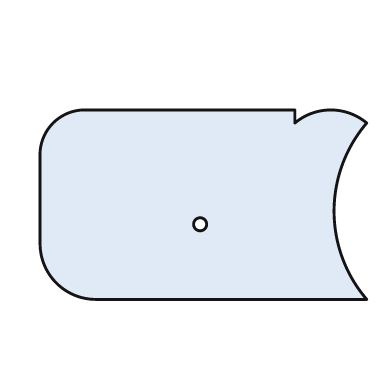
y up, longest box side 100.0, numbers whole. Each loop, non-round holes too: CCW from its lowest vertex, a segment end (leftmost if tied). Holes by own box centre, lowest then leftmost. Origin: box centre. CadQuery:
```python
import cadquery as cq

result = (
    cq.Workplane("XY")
    .moveTo(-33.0, -29.0)
    .lineTo(50.0, -29.0)
    .threePointArc((40.0, -2.0), (50.0, 25.0))
    .threePointArc((39.0, 29.0), (28.0, 25.0))
    .lineTo(28.0, 29.0)
    .lineTo(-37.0, 29.0)
    .threePointArc((-46.0, 25.0), (-50.0, 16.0))
    .lineTo(-50.0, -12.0)
    .threePointArc((-45.0, -24.0), (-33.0, -29.0))
    .close()
    .moveTo(-1.0, -6.0)
    .circle(2.0)
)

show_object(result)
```